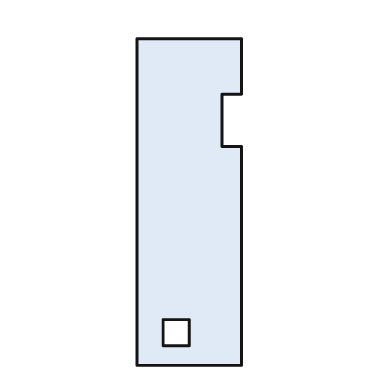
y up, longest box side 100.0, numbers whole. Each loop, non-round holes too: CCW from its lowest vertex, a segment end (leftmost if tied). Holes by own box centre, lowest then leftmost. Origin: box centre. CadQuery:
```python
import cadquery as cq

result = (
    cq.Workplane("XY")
    .moveTo(-16.0, -50.0)
    .lineTo(16.0, -50.0)
    .lineTo(16.0, 17.0)
    .lineTo(10.0, 17.0)
    .lineTo(10.0, 33.0)
    .lineTo(16.0, 33.0)
    .lineTo(16.0, 50.0)
    .lineTo(-16.0, 50.0)
    .close()
    .moveTo(-8.0, -44.0)
    .lineTo(0.0, -44.0)
    .lineTo(0.0, -36.0)
    .lineTo(-8.0, -36.0)
    .close()
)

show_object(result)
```